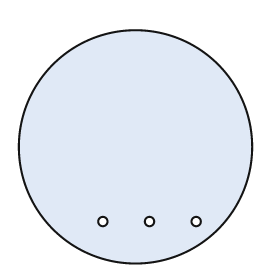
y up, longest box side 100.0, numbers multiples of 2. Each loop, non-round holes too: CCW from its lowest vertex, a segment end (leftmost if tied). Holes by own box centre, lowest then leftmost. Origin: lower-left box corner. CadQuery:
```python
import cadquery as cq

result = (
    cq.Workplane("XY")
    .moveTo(50.0, 50.0)
    .circle(50.0)
    .moveTo(36.0, 18.0)
    .circle(2.0)
    .moveTo(56.0, 18.0)
    .circle(2.0)
    .moveTo(76.0, 18.0)
    .circle(2.0)
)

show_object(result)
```